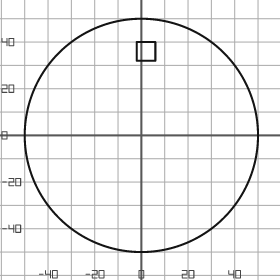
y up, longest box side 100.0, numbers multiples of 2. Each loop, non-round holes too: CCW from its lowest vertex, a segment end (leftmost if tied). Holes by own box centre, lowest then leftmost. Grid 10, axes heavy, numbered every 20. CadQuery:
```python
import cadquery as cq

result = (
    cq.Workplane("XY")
    .moveTo(0.0, 0.0)
    .circle(50.0)
    .moveTo(-2.0, 32.0)
    .lineTo(6.0, 32.0)
    .lineTo(6.0, 40.0)
    .lineTo(-2.0, 40.0)
    .close()
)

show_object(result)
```